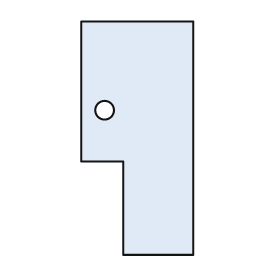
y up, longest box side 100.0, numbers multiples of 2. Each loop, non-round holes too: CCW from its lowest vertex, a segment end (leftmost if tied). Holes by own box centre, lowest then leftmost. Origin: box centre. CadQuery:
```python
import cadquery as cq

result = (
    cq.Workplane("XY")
    .moveTo(-6.0, -50.0)
    .lineTo(24.0, -50.0)
    .lineTo(24.0, 50.0)
    .lineTo(-24.0, 50.0)
    .lineTo(-24.0, -10.0)
    .lineTo(-6.0, -10.0)
    .close()
    .moveTo(-14.0, 12.0)
    .circle(4.0)
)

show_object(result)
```